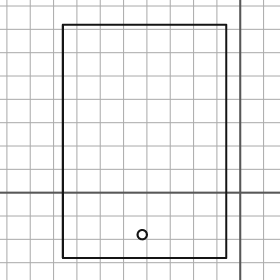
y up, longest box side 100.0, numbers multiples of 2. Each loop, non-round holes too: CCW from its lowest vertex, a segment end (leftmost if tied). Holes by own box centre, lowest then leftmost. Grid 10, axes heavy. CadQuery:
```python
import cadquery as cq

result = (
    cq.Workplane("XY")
    .moveTo(-76.0, -28.0)
    .lineTo(-6.0, -28.0)
    .lineTo(-6.0, 72.0)
    .lineTo(-76.0, 72.0)
    .close()
    .moveTo(-42.0, -18.0)
    .circle(2.0)
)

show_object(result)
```